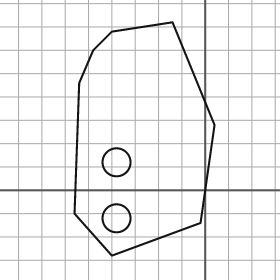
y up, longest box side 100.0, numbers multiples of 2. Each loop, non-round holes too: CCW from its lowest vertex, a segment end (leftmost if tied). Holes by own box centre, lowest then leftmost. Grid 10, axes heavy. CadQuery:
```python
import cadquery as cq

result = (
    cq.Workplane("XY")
    .moveTo(-40.0, -28.0)
    .lineTo(-2.0, -14.0)
    .lineTo(4.0, 28.0)
    .lineTo(-14.0, 72.0)
    .lineTo(-40.0, 68.0)
    .lineTo(-48.0, 60.0)
    .lineTo(-54.0, 46.0)
    .lineTo(-56.0, -10.0)
    .close()
    .moveTo(-38.0, -12.0)
    .circle(6.0)
    .moveTo(-38.0, 12.0)
    .circle(6.0)
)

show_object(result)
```